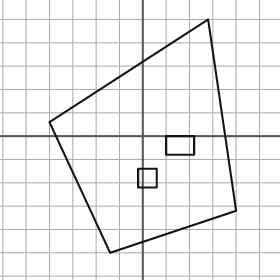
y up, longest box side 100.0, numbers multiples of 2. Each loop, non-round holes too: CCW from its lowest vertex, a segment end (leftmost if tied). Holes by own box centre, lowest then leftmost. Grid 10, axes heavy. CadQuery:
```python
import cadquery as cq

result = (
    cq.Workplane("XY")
    .moveTo(-14.0, -50.0)
    .lineTo(40.0, -32.0)
    .lineTo(28.0, 50.0)
    .lineTo(-40.0, 6.0)
    .close()
    .moveTo(-2.0, -22.0)
    .lineTo(6.0, -22.0)
    .lineTo(6.0, -14.0)
    .lineTo(-2.0, -14.0)
    .close()
    .moveTo(10.0, -8.0)
    .lineTo(22.0, -8.0)
    .lineTo(22.0, 0.0)
    .lineTo(10.0, 0.0)
    .close()
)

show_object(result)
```